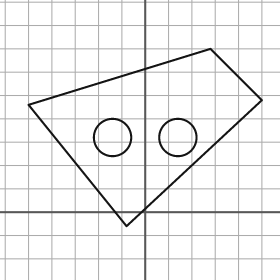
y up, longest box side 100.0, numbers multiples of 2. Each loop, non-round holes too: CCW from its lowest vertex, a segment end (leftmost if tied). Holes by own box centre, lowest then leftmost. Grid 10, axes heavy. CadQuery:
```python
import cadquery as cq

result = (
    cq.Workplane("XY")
    .moveTo(-8.0, -6.0)
    .lineTo(50.0, 48.0)
    .lineTo(28.0, 70.0)
    .lineTo(-50.0, 46.0)
    .close()
    .moveTo(-14.0, 32.0)
    .circle(8.0)
    .moveTo(14.0, 32.0)
    .circle(8.0)
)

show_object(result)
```